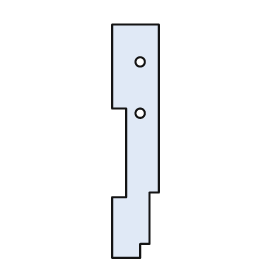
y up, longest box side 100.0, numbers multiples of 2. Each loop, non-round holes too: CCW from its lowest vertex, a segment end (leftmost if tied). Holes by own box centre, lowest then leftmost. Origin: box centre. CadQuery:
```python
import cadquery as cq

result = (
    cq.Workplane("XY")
    .moveTo(-10.0, -50.0)
    .lineTo(2.0, -50.0)
    .lineTo(2.0, -44.0)
    .lineTo(6.0, -44.0)
    .lineTo(6.0, -22.0)
    .lineTo(10.0, -22.0)
    .lineTo(10.0, 50.0)
    .lineTo(-10.0, 50.0)
    .lineTo(-10.0, 14.0)
    .lineTo(-4.0, 14.0)
    .lineTo(-4.0, -24.0)
    .lineTo(-10.0, -24.0)
    .close()
    .moveTo(2.0, 12.0)
    .circle(2.0)
    .moveTo(2.0, 34.0)
    .circle(2.0)
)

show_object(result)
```